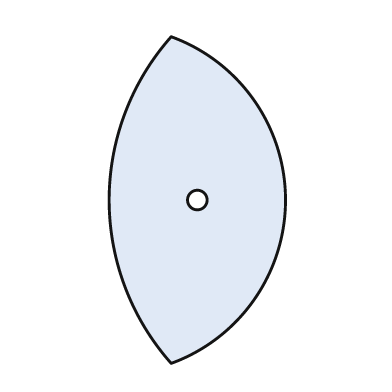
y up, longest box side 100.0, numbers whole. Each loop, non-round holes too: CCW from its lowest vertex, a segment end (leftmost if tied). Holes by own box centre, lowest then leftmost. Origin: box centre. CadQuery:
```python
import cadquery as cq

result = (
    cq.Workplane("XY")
    .moveTo(-8.0, -50.0)
    .threePointArc((27.0, 0.0), (-8.0, 50.0))
    .threePointArc((-27.0, 0.0), (-8.0, -50.0))
    .close()
    .moveTo(0.0, 0.0)
    .circle(3.0)
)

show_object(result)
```